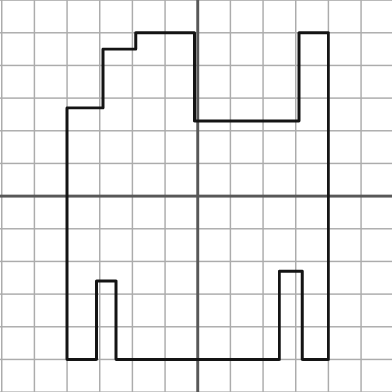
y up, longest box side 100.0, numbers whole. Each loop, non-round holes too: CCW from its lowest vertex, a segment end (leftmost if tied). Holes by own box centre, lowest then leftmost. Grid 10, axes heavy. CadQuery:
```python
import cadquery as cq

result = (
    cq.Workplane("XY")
    .moveTo(-40.0, -50.0)
    .lineTo(-31.0, -50.0)
    .lineTo(-31.0, -26.0)
    .lineTo(-25.0, -26.0)
    .lineTo(-25.0, -50.0)
    .lineTo(25.0, -50.0)
    .lineTo(25.0, -23.0)
    .lineTo(32.0, -23.0)
    .lineTo(32.0, -50.0)
    .lineTo(40.0, -50.0)
    .lineTo(40.0, 50.0)
    .lineTo(31.0, 50.0)
    .lineTo(31.0, 23.0)
    .lineTo(-1.0, 23.0)
    .lineTo(-1.0, 50.0)
    .lineTo(-19.0, 50.0)
    .lineTo(-19.0, 45.0)
    .lineTo(-29.0, 45.0)
    .lineTo(-29.0, 27.0)
    .lineTo(-40.0, 27.0)
    .close()
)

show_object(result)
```